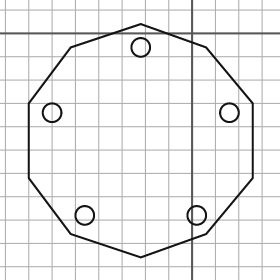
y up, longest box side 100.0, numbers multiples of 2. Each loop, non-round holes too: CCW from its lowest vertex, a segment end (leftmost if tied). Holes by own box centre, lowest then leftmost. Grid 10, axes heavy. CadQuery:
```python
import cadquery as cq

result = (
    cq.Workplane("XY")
    .moveTo(-22.0, -96.0)
    .lineTo(6.0, -86.0)
    .lineTo(26.0, -62.0)
    .lineTo(26.0, -30.0)
    .lineTo(6.0, -6.0)
    .lineTo(-22.0, 4.0)
    .lineTo(-52.0, -6.0)
    .lineTo(-70.0, -30.0)
    .lineTo(-70.0, -62.0)
    .lineTo(-52.0, -86.0)
    .close()
    .moveTo(-46.0, -78.0)
    .circle(4.0)
    .moveTo(2.0, -78.0)
    .circle(4.0)
    .moveTo(-60.0, -34.0)
    .circle(4.0)
    .moveTo(16.0, -34.0)
    .circle(4.0)
    .moveTo(-22.0, -6.0)
    .circle(4.0)
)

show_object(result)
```